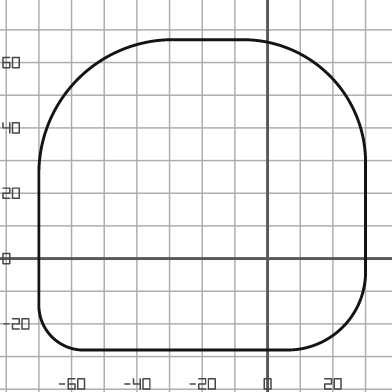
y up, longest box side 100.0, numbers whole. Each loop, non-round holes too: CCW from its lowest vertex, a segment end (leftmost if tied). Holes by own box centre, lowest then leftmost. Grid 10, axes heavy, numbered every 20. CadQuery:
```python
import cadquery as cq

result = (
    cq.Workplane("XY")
    .moveTo(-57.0, -28.0)
    .lineTo(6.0, -28.0)
    .threePointArc((23.0, -21.0), (30.0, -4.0))
    .lineTo(30.0, 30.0)
    .threePointArc((19.0, 56.0), (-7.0, 67.0))
    .lineTo(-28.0, 67.0)
    .threePointArc((-58.0, 55.0), (-70.0, 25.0))
    .lineTo(-70.0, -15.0)
    .threePointArc((-66.0, -24.0), (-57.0, -28.0))
    .close()
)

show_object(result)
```